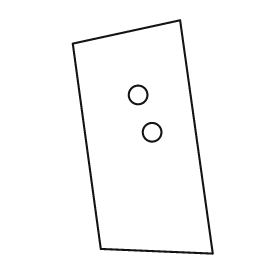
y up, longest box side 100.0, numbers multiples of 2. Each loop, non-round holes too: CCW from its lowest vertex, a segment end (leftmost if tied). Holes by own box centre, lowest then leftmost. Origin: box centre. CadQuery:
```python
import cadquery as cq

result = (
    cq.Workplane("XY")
    .moveTo(30.0, -50.0)
    .lineTo(16.0, 50.0)
    .lineTo(-30.0, 40.0)
    .lineTo(-18.0, -48.0)
    .close()
    .moveTo(4.0, 2.0)
    .circle(4.0)
    .moveTo(-2.0, 18.0)
    .circle(4.0)
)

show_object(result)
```